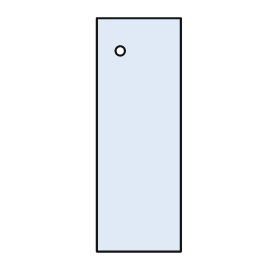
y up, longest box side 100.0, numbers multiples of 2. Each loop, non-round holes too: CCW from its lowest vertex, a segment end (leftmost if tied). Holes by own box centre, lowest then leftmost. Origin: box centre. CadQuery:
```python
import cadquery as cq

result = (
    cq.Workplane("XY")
    .moveTo(-18.0, -50.0)
    .lineTo(18.0, -50.0)
    .lineTo(18.0, 50.0)
    .lineTo(-18.0, 50.0)
    .close()
    .moveTo(-8.0, 36.0)
    .circle(2.0)
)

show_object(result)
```